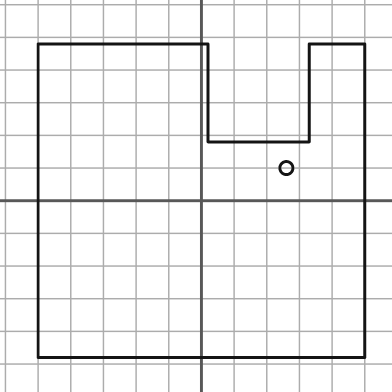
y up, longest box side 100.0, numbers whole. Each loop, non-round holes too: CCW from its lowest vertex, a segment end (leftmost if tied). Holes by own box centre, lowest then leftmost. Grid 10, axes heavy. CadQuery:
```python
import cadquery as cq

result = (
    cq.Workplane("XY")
    .moveTo(-50.0, -48.0)
    .lineTo(50.0, -48.0)
    .lineTo(50.0, 48.0)
    .lineTo(33.0, 48.0)
    .lineTo(33.0, 18.0)
    .lineTo(2.0, 18.0)
    .lineTo(2.0, 48.0)
    .lineTo(-50.0, 48.0)
    .close()
    .moveTo(26.0, 10.0)
    .circle(2.0)
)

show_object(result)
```